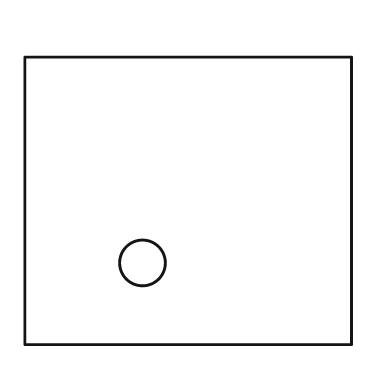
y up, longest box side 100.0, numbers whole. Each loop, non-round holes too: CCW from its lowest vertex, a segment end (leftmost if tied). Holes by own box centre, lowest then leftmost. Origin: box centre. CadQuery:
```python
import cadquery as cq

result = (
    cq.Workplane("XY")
    .moveTo(-50.0, -44.0)
    .lineTo(50.0, -44.0)
    .lineTo(50.0, 44.0)
    .lineTo(-50.0, 44.0)
    .close()
    .moveTo(-14.0, -19.0)
    .circle(7.0)
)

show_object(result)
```